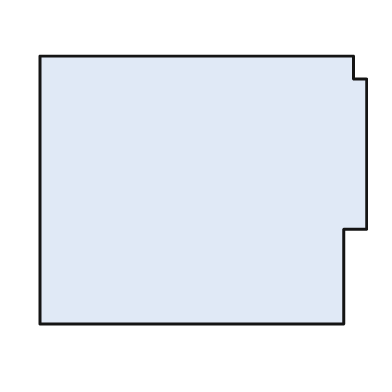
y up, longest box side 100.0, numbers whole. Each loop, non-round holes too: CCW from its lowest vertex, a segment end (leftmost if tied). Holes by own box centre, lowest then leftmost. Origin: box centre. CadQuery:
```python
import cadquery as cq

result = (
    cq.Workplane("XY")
    .moveTo(-50.0, -41.0)
    .lineTo(43.0, -41.0)
    .lineTo(43.0, -12.0)
    .lineTo(50.0, -12.0)
    .lineTo(50.0, 34.0)
    .lineTo(46.0, 34.0)
    .lineTo(46.0, 41.0)
    .lineTo(-50.0, 41.0)
    .close()
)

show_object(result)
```